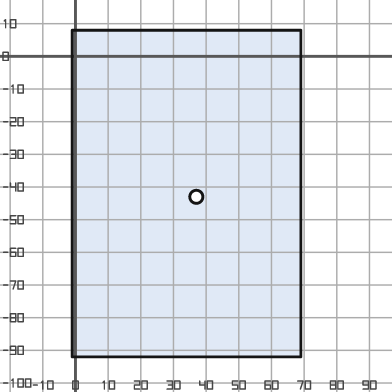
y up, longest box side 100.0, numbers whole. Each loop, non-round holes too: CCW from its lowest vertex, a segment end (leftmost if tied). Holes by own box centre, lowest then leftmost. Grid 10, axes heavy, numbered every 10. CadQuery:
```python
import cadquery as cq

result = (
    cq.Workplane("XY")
    .moveTo(-1.0, -92.0)
    .lineTo(69.0, -92.0)
    .lineTo(69.0, 8.0)
    .lineTo(-1.0, 8.0)
    .close()
    .moveTo(37.0, -43.0)
    .circle(2.0)
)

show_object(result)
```